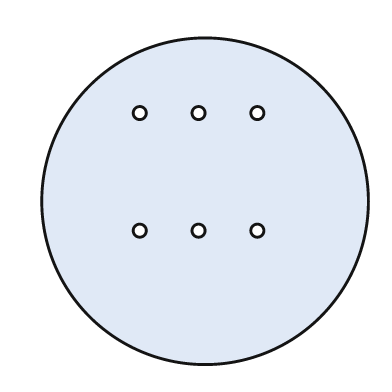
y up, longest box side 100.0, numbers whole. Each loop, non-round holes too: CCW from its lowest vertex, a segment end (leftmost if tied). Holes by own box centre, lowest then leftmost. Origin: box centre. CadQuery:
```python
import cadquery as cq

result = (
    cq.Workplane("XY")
    .moveTo(0.0, 0.0)
    .circle(50.0)
    .moveTo(-20.0, -9.0)
    .circle(2.0)
    .moveTo(-2.0, -9.0)
    .circle(2.0)
    .moveTo(16.0, -9.0)
    .circle(2.0)
    .moveTo(-20.0, 27.0)
    .circle(2.0)
    .moveTo(-2.0, 27.0)
    .circle(2.0)
    .moveTo(16.0, 27.0)
    .circle(2.0)
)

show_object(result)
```